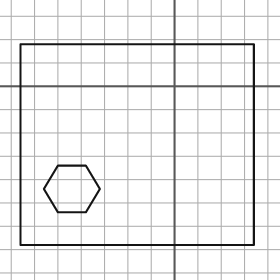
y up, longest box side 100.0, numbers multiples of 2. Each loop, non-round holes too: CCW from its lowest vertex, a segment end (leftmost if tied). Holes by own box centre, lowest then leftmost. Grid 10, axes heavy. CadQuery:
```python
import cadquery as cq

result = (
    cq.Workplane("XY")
    .moveTo(-66.0, -68.0)
    .lineTo(34.0, -68.0)
    .lineTo(34.0, 18.0)
    .lineTo(-66.0, 18.0)
    .close()
    .moveTo(-50.0, -54.0)
    .lineTo(-38.0, -54.0)
    .lineTo(-32.0, -44.0)
    .lineTo(-38.0, -34.0)
    .lineTo(-50.0, -34.0)
    .lineTo(-56.0, -44.0)
    .close()
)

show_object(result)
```